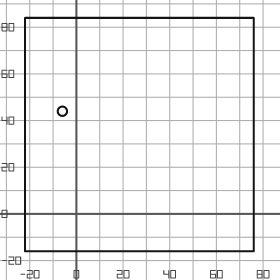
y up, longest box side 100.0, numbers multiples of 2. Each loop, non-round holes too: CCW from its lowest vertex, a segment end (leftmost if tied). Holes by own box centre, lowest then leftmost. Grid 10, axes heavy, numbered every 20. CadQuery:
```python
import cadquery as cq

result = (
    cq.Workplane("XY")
    .moveTo(-22.0, -16.0)
    .lineTo(76.0, -16.0)
    .lineTo(76.0, 84.0)
    .lineTo(-22.0, 84.0)
    .close()
    .moveTo(-6.0, 44.0)
    .circle(2.0)
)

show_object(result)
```